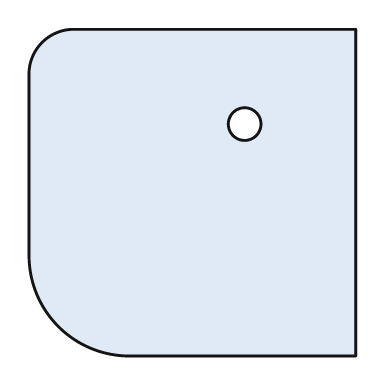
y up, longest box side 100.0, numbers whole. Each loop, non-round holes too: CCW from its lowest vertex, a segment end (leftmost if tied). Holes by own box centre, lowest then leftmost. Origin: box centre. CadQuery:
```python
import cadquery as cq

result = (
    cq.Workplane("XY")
    .moveTo(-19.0, -50.0)
    .lineTo(50.0, -50.0)
    .lineTo(50.0, 50.0)
    .lineTo(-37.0, 50.0)
    .threePointArc((-46.0, 46.0), (-50.0, 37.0))
    .lineTo(-50.0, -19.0)
    .threePointArc((-41.0, -41.0), (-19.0, -50.0))
    .close()
    .moveTo(16.0, 21.0)
    .circle(5.0)
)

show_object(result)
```